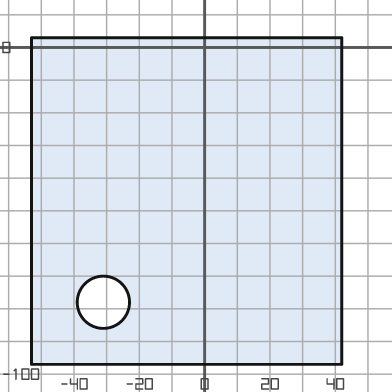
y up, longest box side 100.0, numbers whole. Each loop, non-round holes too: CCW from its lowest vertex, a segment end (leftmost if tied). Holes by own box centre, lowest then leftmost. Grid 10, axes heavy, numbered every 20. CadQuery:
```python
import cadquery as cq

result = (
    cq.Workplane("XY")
    .moveTo(-53.0, -97.0)
    .lineTo(42.0, -97.0)
    .lineTo(42.0, 3.0)
    .lineTo(-53.0, 3.0)
    .close()
    .moveTo(-31.0, -78.0)
    .circle(8.0)
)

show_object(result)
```